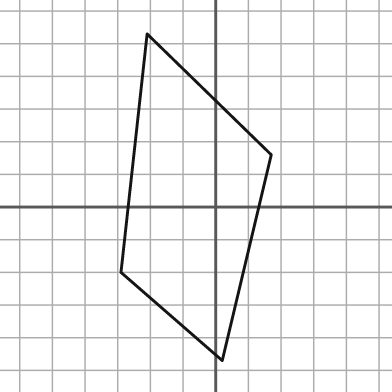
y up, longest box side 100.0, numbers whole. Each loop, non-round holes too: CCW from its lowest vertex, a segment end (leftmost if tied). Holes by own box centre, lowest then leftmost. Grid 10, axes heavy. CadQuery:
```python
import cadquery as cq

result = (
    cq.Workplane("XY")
    .moveTo(2.0, -47.0)
    .lineTo(17.0, 16.0)
    .lineTo(-21.0, 53.0)
    .lineTo(-29.0, -20.0)
    .close()
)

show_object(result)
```